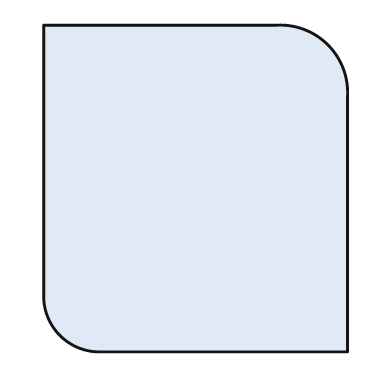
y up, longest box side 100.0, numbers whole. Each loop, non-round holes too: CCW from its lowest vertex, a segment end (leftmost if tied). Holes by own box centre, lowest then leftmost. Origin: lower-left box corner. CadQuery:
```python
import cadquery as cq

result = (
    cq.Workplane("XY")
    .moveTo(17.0, 0.0)
    .lineTo(93.0, 0.0)
    .lineTo(93.0, 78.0)
    .threePointArc((87.0, 94.0), (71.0, 100.0))
    .lineTo(0.0, 100.0)
    .lineTo(0.0, 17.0)
    .threePointArc((5.0, 5.0), (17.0, 0.0))
    .close()
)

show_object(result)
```